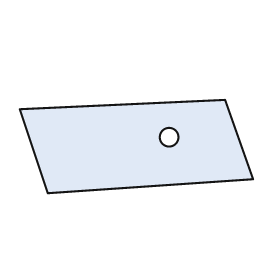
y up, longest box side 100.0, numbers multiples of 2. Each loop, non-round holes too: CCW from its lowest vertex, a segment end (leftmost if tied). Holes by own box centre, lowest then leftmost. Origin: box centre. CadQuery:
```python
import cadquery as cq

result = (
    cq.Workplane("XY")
    .moveTo(-38.0, -20.0)
    .lineTo(50.0, -14.0)
    .lineTo(38.0, 20.0)
    .lineTo(-50.0, 16.0)
    .close()
    .moveTo(14.0, 4.0)
    .circle(4.0)
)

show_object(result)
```